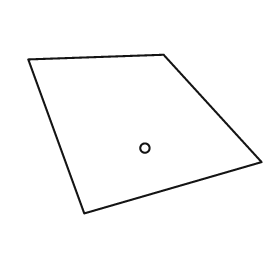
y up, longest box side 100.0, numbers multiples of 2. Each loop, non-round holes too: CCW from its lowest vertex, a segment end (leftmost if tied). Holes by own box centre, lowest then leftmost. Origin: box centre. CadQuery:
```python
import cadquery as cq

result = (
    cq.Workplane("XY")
    .moveTo(-26.0, -34.0)
    .lineTo(50.0, -12.0)
    .lineTo(8.0, 34.0)
    .lineTo(-50.0, 32.0)
    .close()
    .moveTo(0.0, -6.0)
    .circle(2.0)
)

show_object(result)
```